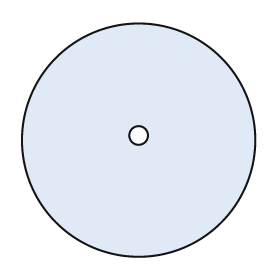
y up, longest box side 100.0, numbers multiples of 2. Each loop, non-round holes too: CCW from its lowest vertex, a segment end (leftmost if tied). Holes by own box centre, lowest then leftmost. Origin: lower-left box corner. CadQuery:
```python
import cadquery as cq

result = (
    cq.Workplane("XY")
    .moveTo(50.0, 50.0)
    .circle(50.0)
    .moveTo(50.0, 52.0)
    .circle(4.0)
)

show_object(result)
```